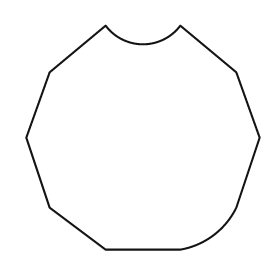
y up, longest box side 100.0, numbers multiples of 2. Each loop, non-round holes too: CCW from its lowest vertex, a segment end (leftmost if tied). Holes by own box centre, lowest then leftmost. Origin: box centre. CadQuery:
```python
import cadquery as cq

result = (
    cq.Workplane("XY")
    .moveTo(-16.0, -48.0)
    .lineTo(16.0, -48.0)
    .threePointArc((30.0, -42.0), (40.0, -30.0))
    .lineTo(50.0, 0.0)
    .lineTo(40.0, 28.0)
    .lineTo(16.0, 48.0)
    .threePointArc((0.0, 40.0), (-16.0, 48.0))
    .lineTo(-40.0, 28.0)
    .lineTo(-50.0, 0.0)
    .lineTo(-40.0, -30.0)
    .close()
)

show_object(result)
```